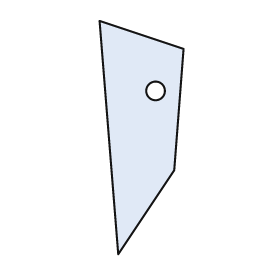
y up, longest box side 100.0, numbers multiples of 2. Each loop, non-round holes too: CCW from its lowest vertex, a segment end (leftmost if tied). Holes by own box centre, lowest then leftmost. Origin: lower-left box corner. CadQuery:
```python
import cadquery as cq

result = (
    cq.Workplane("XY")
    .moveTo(8.0, 0.0)
    .lineTo(32.0, 36.0)
    .lineTo(36.0, 88.0)
    .lineTo(0.0, 100.0)
    .close()
    .moveTo(24.0, 70.0)
    .circle(4.0)
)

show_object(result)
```